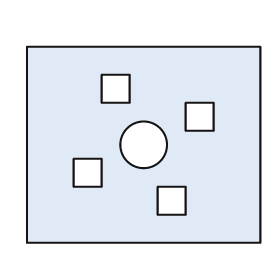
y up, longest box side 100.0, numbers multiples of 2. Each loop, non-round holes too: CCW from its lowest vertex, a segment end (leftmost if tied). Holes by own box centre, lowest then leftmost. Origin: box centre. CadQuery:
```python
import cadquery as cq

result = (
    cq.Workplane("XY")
    .moveTo(-50.0, -42.0)
    .lineTo(50.0, -42.0)
    .lineTo(50.0, 42.0)
    .lineTo(-50.0, 42.0)
    .close()
    .moveTo(6.0, -30.0)
    .lineTo(18.0, -30.0)
    .lineTo(18.0, -18.0)
    .lineTo(6.0, -18.0)
    .close()
    .moveTo(-30.0, -18.0)
    .lineTo(-18.0, -18.0)
    .lineTo(-18.0, -6.0)
    .lineTo(-30.0, -6.0)
    .close()
    .moveTo(0.0, 0.0)
    .circle(10.0)
    .moveTo(18.0, 6.0)
    .lineTo(30.0, 6.0)
    .lineTo(30.0, 18.0)
    .lineTo(18.0, 18.0)
    .close()
    .moveTo(-18.0, 18.0)
    .lineTo(-6.0, 18.0)
    .lineTo(-6.0, 30.0)
    .lineTo(-18.0, 30.0)
    .close()
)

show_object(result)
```